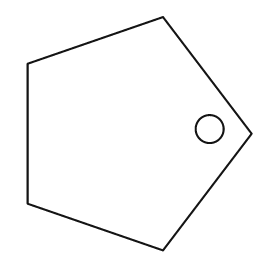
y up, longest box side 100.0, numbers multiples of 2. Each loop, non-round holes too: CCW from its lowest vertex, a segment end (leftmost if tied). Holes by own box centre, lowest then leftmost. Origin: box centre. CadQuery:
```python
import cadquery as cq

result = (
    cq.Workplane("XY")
    .moveTo(10.0, -50.0)
    .lineTo(48.0, 0.0)
    .lineTo(10.0, 50.0)
    .lineTo(-48.0, 30.0)
    .lineTo(-48.0, -30.0)
    .close()
    .moveTo(30.0, 2.0)
    .circle(6.0)
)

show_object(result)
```